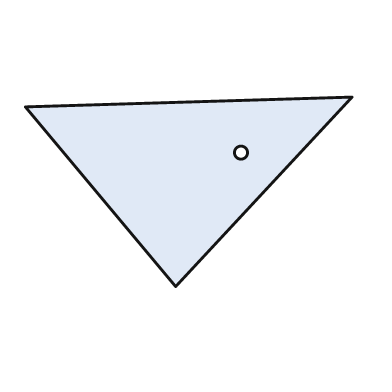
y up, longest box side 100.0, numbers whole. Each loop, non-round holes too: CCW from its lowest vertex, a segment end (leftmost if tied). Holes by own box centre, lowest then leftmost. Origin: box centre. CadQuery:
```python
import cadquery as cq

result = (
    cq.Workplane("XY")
    .moveTo(-4.0, -29.0)
    .lineTo(50.0, 29.0)
    .lineTo(-50.0, 26.0)
    .close()
    .moveTo(16.0, 12.0)
    .circle(2.0)
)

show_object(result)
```